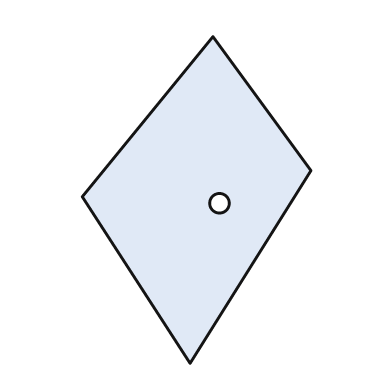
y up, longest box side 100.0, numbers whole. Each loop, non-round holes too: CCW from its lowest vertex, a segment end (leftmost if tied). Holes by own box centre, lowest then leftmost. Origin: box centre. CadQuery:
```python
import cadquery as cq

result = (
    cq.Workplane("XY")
    .moveTo(-2.0, -50.0)
    .lineTo(35.0, 9.0)
    .lineTo(5.0, 50.0)
    .lineTo(-35.0, 1.0)
    .close()
    .moveTo(7.0, -1.0)
    .circle(3.0)
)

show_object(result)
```